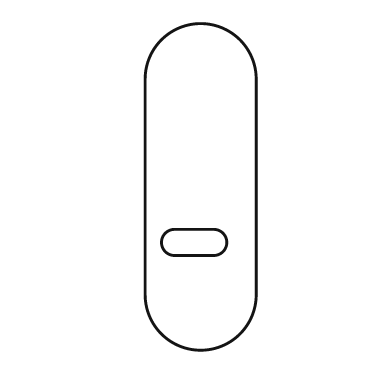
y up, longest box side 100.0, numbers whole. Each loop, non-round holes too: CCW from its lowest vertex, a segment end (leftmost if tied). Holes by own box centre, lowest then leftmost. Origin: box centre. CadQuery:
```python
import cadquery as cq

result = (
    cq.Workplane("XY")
    .moveTo(-17.0, -33.0)
    .threePointArc((0.0, -50.0), (17.0, -33.0))
    .lineTo(17.0, 33.0)
    .threePointArc((0.0, 50.0), (-17.0, 33.0))
    .close()
    .moveTo(-8.0, -21.0)
    .lineTo(4.0, -21.0)
    .threePointArc((8.0, -17.0), (4.0, -13.0))
    .lineTo(-8.0, -13.0)
    .threePointArc((-12.0, -17.0), (-8.0, -21.0))
    .close()
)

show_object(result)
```